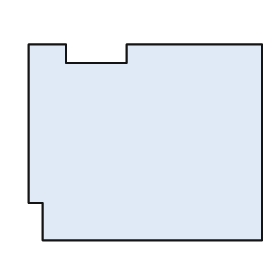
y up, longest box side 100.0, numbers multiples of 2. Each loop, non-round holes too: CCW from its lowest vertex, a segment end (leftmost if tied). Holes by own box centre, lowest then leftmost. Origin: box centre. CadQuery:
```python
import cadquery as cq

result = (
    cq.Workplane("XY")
    .moveTo(-44.0, -42.0)
    .lineTo(50.0, -42.0)
    .lineTo(50.0, 42.0)
    .lineTo(-8.0, 42.0)
    .lineTo(-8.0, 34.0)
    .lineTo(-34.0, 34.0)
    .lineTo(-34.0, 42.0)
    .lineTo(-50.0, 42.0)
    .lineTo(-50.0, -26.0)
    .lineTo(-44.0, -26.0)
    .close()
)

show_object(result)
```